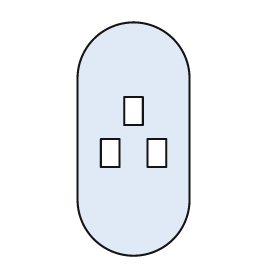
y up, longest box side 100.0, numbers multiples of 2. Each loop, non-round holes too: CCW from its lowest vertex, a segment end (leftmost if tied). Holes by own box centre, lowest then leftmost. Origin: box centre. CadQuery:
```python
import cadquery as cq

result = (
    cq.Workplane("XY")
    .moveTo(-24.0, -26.0)
    .threePointArc((0.0, -50.0), (24.0, -26.0))
    .lineTo(24.0, 26.0)
    .threePointArc((0.0, 50.0), (-24.0, 26.0))
    .close()
    .moveTo(-14.0, -12.0)
    .lineTo(-6.0, -12.0)
    .lineTo(-6.0, 0.0)
    .lineTo(-14.0, 0.0)
    .close()
    .moveTo(6.0, -12.0)
    .lineTo(14.0, -12.0)
    .lineTo(14.0, 0.0)
    .lineTo(6.0, 0.0)
    .close()
    .moveTo(-4.0, 6.0)
    .lineTo(4.0, 6.0)
    .lineTo(4.0, 18.0)
    .lineTo(-4.0, 18.0)
    .close()
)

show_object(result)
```